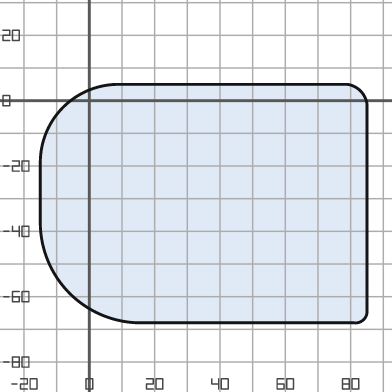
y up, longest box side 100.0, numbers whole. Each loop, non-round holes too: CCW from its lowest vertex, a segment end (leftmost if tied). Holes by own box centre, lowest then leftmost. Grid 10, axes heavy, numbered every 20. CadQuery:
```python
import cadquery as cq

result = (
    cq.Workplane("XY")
    .moveTo(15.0, -68.0)
    .lineTo(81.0, -68.0)
    .threePointArc((84.0, -67.0), (85.0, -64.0))
    .lineTo(85.0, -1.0)
    .threePointArc((83.0, 3.0), (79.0, 5.0))
    .lineTo(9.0, 5.0)
    .threePointArc((-8.0, -2.0), (-15.0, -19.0))
    .lineTo(-15.0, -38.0)
    .threePointArc((-6.0, -59.0), (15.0, -68.0))
    .close()
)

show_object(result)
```